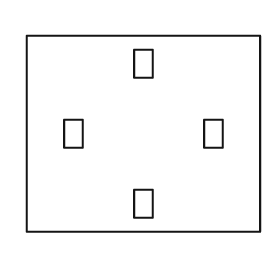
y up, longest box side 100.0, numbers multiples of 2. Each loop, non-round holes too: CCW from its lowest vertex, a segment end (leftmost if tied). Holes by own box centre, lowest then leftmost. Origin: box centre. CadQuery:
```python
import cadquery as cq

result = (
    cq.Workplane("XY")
    .moveTo(-50.0, -42.0)
    .lineTo(50.0, -42.0)
    .lineTo(50.0, 42.0)
    .lineTo(-50.0, 42.0)
    .close()
    .moveTo(-4.0, -36.0)
    .lineTo(4.0, -36.0)
    .lineTo(4.0, -24.0)
    .lineTo(-4.0, -24.0)
    .close()
    .moveTo(-34.0, -6.0)
    .lineTo(-26.0, -6.0)
    .lineTo(-26.0, 6.0)
    .lineTo(-34.0, 6.0)
    .close()
    .moveTo(26.0, -6.0)
    .lineTo(34.0, -6.0)
    .lineTo(34.0, 6.0)
    .lineTo(26.0, 6.0)
    .close()
    .moveTo(-4.0, 24.0)
    .lineTo(4.0, 24.0)
    .lineTo(4.0, 36.0)
    .lineTo(-4.0, 36.0)
    .close()
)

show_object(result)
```